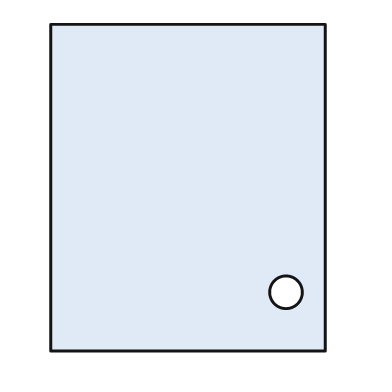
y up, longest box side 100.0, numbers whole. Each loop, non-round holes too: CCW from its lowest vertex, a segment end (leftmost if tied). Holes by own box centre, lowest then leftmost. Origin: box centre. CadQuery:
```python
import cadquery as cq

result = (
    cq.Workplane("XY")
    .moveTo(-42.0, -50.0)
    .lineTo(42.0, -50.0)
    .lineTo(42.0, 50.0)
    .lineTo(-42.0, 50.0)
    .close()
    .moveTo(30.0, -32.0)
    .circle(5.0)
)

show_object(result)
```